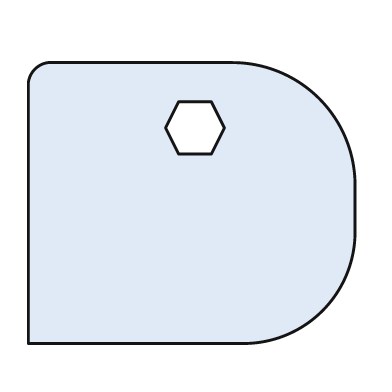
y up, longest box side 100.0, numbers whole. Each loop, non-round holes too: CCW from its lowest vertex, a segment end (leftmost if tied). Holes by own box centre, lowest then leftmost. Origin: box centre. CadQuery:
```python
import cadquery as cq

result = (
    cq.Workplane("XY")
    .moveTo(-50.0, -43.0)
    .lineTo(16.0, -43.0)
    .threePointArc((40.0, -33.0), (50.0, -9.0))
    .lineTo(50.0, 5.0)
    .threePointArc((39.0, 32.0), (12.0, 43.0))
    .lineTo(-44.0, 43.0)
    .threePointArc((-48.0, 41.0), (-50.0, 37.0))
    .close()
    .moveTo(-4.0, 15.0)
    .lineTo(6.0, 15.0)
    .lineTo(10.0, 23.0)
    .lineTo(6.0, 31.0)
    .lineTo(-4.0, 31.0)
    .lineTo(-8.0, 23.0)
    .close()
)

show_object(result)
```